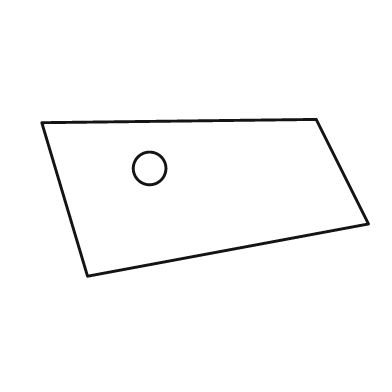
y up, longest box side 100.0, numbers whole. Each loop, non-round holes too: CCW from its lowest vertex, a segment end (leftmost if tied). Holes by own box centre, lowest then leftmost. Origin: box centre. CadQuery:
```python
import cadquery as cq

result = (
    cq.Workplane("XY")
    .moveTo(-36.0, -24.0)
    .lineTo(50.0, -8.0)
    .lineTo(34.0, 24.0)
    .lineTo(-50.0, 23.0)
    .close()
    .moveTo(-17.0, 9.0)
    .circle(5.0)
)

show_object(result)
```